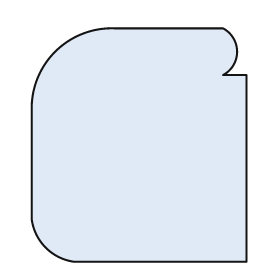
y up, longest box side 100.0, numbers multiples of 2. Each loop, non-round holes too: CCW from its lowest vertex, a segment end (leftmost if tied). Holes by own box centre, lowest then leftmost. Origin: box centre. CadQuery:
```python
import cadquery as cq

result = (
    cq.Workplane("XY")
    .moveTo(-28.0, -50.0)
    .lineTo(46.0, -50.0)
    .lineTo(46.0, 30.0)
    .lineTo(36.0, 30.0)
    .threePointArc((42.0, 40.0), (36.0, 50.0))
    .lineTo(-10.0, 50.0)
    .threePointArc((-36.0, 40.0), (-46.0, 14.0))
    .lineTo(-46.0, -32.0)
    .threePointArc((-40.0, -44.0), (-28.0, -50.0))
    .close()
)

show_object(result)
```